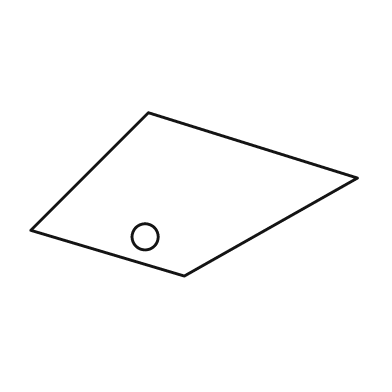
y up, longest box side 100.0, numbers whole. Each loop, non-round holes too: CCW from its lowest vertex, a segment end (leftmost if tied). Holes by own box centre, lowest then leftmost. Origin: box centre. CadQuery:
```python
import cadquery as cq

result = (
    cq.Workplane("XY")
    .moveTo(-3.0, -25.0)
    .lineTo(50.0, 5.0)
    .lineTo(-14.0, 25.0)
    .lineTo(-50.0, -11.0)
    .close()
    .moveTo(-15.0, -13.0)
    .circle(4.0)
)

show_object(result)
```